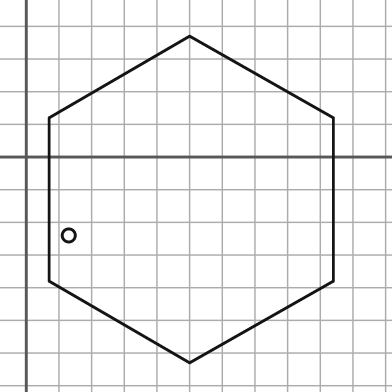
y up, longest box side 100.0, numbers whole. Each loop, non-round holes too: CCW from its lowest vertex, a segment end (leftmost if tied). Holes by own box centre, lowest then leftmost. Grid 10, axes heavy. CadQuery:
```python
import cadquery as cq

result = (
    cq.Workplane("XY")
    .moveTo(50.0, -63.0)
    .lineTo(94.0, -38.0)
    .lineTo(94.0, 12.0)
    .lineTo(50.0, 37.0)
    .lineTo(7.0, 12.0)
    .lineTo(7.0, -38.0)
    .close()
    .moveTo(13.0, -24.0)
    .circle(2.0)
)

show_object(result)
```